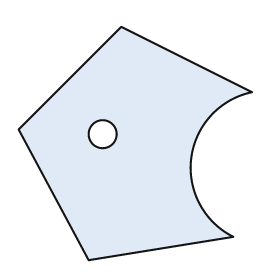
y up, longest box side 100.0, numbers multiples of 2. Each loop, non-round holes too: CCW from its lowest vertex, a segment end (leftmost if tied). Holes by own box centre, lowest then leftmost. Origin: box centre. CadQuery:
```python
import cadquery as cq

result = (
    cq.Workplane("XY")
    .moveTo(-20.0, -50.0)
    .lineTo(42.0, -40.0)
    .threePointArc((24.0, -6.0), (50.0, 22.0))
    .lineTo(-6.0, 50.0)
    .lineTo(-50.0, 6.0)
    .close()
    .moveTo(-14.0, 4.0)
    .circle(6.0)
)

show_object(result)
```